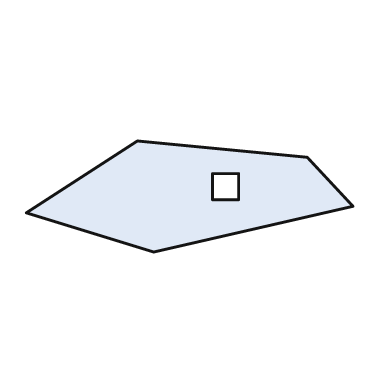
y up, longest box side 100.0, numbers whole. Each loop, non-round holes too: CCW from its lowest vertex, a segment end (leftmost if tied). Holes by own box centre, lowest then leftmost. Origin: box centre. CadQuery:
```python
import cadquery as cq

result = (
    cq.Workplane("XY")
    .moveTo(-11.0, -17.0)
    .lineTo(50.0, -3.0)
    .lineTo(36.0, 12.0)
    .lineTo(-16.0, 17.0)
    .lineTo(-50.0, -5.0)
    .close()
    .moveTo(7.0, -1.0)
    .lineTo(15.0, -1.0)
    .lineTo(15.0, 7.0)
    .lineTo(7.0, 7.0)
    .close()
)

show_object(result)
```